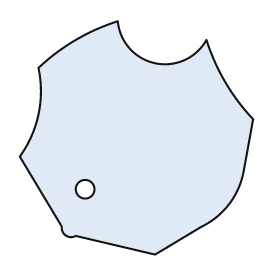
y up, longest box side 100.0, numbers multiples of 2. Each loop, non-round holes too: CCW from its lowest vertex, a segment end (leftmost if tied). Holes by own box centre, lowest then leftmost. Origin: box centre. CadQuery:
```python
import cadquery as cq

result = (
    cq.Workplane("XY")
    .moveTo(8.0, -50.0)
    .lineTo(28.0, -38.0)
    .threePointArc((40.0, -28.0), (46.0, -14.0))
    .lineTo(50.0, 8.0)
    .threePointArc((38.0, 24.0), (30.0, 42.0))
    .threePointArc((8.0, 32.0), (-8.0, 50.0))
    .threePointArc((-26.0, 42.0), (-42.0, 30.0))
    .threePointArc((-42.0, 10.0), (-50.0, -8.0))
    .lineTo(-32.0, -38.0)
    .threePointArc((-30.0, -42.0), (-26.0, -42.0))
    .close()
    .moveTo(-22.0, -22.0)
    .circle(4.0)
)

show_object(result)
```